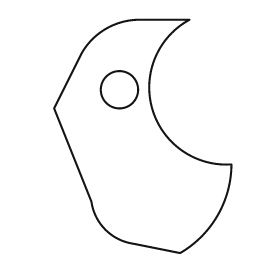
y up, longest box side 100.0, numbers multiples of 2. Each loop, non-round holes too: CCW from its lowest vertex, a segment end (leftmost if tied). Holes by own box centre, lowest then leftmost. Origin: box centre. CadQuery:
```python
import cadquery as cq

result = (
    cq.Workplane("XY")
    .moveTo(16.0, -50.0)
    .threePointArc((32.0, -34.0), (38.0, -12.0))
    .threePointArc((4.0, 12.0), (20.0, 50.0))
    .lineTo(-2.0, 50.0)
    .threePointArc((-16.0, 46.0), (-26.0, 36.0))
    .lineTo(-38.0, 12.0)
    .lineTo(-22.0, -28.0)
    .threePointArc((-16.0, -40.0), (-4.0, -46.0))
    .close()
    .moveTo(-10.0, 20.0)
    .circle(8.0)
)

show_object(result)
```